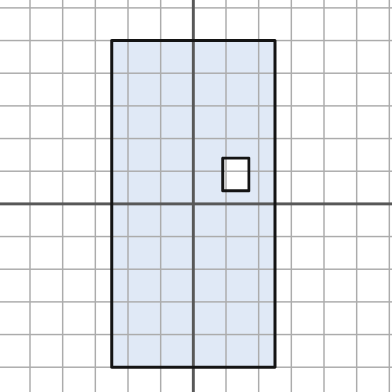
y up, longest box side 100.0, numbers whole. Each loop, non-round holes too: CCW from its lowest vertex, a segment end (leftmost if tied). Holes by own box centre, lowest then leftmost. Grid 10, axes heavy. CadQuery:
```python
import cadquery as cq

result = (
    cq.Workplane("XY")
    .moveTo(-25.0, -50.0)
    .lineTo(25.0, -50.0)
    .lineTo(25.0, 50.0)
    .lineTo(-25.0, 50.0)
    .close()
    .moveTo(9.0, 4.0)
    .lineTo(17.0, 4.0)
    .lineTo(17.0, 14.0)
    .lineTo(9.0, 14.0)
    .close()
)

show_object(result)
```